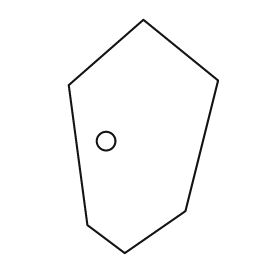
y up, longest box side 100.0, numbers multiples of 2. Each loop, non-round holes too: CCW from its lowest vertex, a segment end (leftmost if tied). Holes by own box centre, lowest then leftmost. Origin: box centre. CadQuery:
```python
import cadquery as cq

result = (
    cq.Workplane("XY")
    .moveTo(-8.0, -50.0)
    .lineTo(18.0, -32.0)
    .lineTo(32.0, 24.0)
    .lineTo(0.0, 50.0)
    .lineTo(-32.0, 22.0)
    .lineTo(-24.0, -38.0)
    .close()
    .moveTo(-16.0, -2.0)
    .circle(4.0)
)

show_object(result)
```